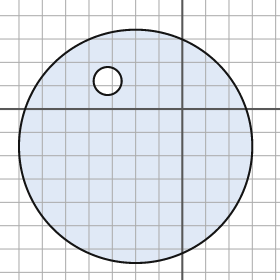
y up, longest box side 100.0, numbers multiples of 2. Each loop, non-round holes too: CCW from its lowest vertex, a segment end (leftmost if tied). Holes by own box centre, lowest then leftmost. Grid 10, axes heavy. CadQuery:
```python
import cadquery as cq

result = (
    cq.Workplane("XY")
    .moveTo(-20.0, -16.0)
    .circle(50.0)
    .moveTo(-32.0, 12.0)
    .circle(6.0)
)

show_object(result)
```